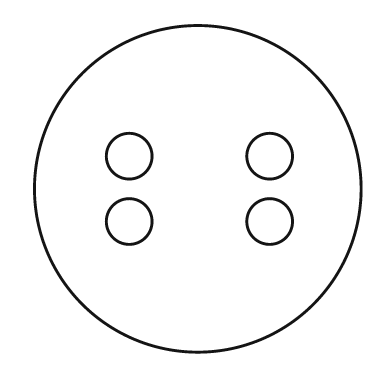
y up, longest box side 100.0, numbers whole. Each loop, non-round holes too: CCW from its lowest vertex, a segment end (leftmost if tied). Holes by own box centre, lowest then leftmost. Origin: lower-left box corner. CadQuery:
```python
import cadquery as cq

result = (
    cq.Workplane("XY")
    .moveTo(50.0, 50.0)
    .circle(50.0)
    .moveTo(29.0, 40.0)
    .circle(7.0)
    .moveTo(72.0, 40.0)
    .circle(7.0)
    .moveTo(29.0, 60.0)
    .circle(7.0)
    .moveTo(72.0, 60.0)
    .circle(7.0)
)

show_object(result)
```